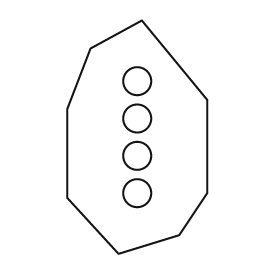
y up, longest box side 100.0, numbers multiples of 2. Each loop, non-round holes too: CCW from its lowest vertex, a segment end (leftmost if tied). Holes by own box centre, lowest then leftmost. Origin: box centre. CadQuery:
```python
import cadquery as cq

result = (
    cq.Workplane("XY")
    .moveTo(-8.0, -50.0)
    .lineTo(18.0, -42.0)
    .lineTo(30.0, -24.0)
    .lineTo(30.0, 16.0)
    .lineTo(2.0, 50.0)
    .lineTo(-20.0, 38.0)
    .lineTo(-30.0, 12.0)
    .lineTo(-30.0, -26.0)
    .close()
    .moveTo(0.0, -24.0)
    .circle(6.0)
    .moveTo(0.0, -8.0)
    .circle(6.0)
    .moveTo(0.0, 8.0)
    .circle(6.0)
    .moveTo(0.0, 24.0)
    .circle(6.0)
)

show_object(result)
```